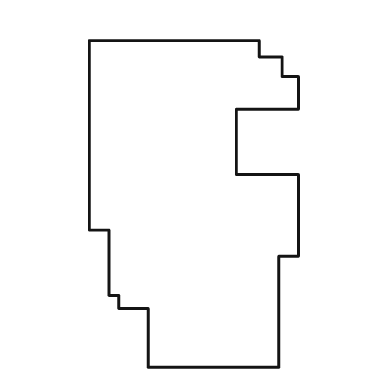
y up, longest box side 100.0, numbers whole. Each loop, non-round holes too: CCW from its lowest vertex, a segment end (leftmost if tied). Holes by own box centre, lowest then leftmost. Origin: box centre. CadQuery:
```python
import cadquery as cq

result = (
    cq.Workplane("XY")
    .moveTo(-14.0, -50.0)
    .lineTo(26.0, -50.0)
    .lineTo(26.0, -16.0)
    .lineTo(32.0, -16.0)
    .lineTo(32.0, 9.0)
    .lineTo(13.0, 9.0)
    .lineTo(13.0, 29.0)
    .lineTo(32.0, 29.0)
    .lineTo(32.0, 39.0)
    .lineTo(27.0, 39.0)
    .lineTo(27.0, 45.0)
    .lineTo(20.0, 45.0)
    .lineTo(20.0, 50.0)
    .lineTo(-32.0, 50.0)
    .lineTo(-32.0, -8.0)
    .lineTo(-26.0, -8.0)
    .lineTo(-26.0, -28.0)
    .lineTo(-23.0, -28.0)
    .lineTo(-23.0, -32.0)
    .lineTo(-14.0, -32.0)
    .close()
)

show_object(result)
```